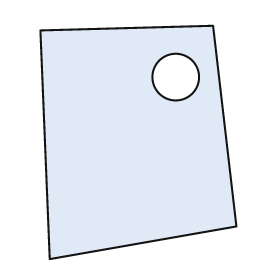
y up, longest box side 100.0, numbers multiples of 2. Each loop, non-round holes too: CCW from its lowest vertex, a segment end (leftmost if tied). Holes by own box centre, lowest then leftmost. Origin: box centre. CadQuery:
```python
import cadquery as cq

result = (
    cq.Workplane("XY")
    .moveTo(-38.0, -50.0)
    .lineTo(42.0, -36.0)
    .lineTo(32.0, 50.0)
    .lineTo(-42.0, 48.0)
    .close()
    .moveTo(16.0, 28.0)
    .circle(10.0)
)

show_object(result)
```